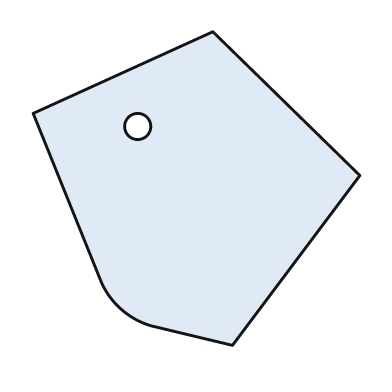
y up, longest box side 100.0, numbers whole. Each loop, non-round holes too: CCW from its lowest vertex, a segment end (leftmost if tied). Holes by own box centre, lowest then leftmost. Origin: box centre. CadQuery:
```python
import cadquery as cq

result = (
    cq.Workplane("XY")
    .moveTo(11.0, -48.0)
    .lineTo(50.0, 4.0)
    .lineTo(5.0, 48.0)
    .lineTo(-50.0, 23.0)
    .lineTo(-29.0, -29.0)
    .threePointArc((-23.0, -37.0), (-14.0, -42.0))
    .close()
    .moveTo(-18.0, 19.0)
    .circle(4.0)
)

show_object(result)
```